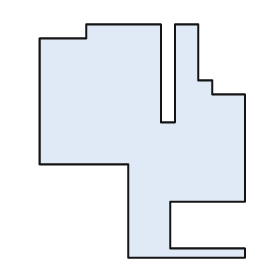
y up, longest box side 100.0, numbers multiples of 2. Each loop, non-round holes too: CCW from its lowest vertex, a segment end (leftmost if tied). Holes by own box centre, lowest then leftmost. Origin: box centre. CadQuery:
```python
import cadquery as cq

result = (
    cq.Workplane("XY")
    .moveTo(-6.0, -50.0)
    .lineTo(44.0, -50.0)
    .lineTo(44.0, -46.0)
    .lineTo(12.0, -46.0)
    .lineTo(12.0, -26.0)
    .lineTo(44.0, -26.0)
    .lineTo(44.0, 20.0)
    .lineTo(30.0, 20.0)
    .lineTo(30.0, 26.0)
    .lineTo(24.0, 26.0)
    .lineTo(24.0, 50.0)
    .lineTo(14.0, 50.0)
    .lineTo(14.0, 8.0)
    .lineTo(8.0, 8.0)
    .lineTo(8.0, 50.0)
    .lineTo(-24.0, 50.0)
    .lineTo(-24.0, 44.0)
    .lineTo(-44.0, 44.0)
    .lineTo(-44.0, -10.0)
    .lineTo(-6.0, -10.0)
    .close()
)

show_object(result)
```